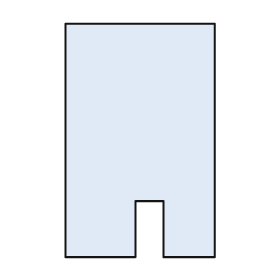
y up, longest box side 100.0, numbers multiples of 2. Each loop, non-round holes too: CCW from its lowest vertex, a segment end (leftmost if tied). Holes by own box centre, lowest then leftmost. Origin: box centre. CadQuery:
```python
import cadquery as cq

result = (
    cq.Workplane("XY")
    .moveTo(-32.0, -50.0)
    .lineTo(-2.0, -50.0)
    .lineTo(-2.0, -26.0)
    .lineTo(10.0, -26.0)
    .lineTo(10.0, -50.0)
    .lineTo(32.0, -50.0)
    .lineTo(32.0, 50.0)
    .lineTo(-32.0, 50.0)
    .close()
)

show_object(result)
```